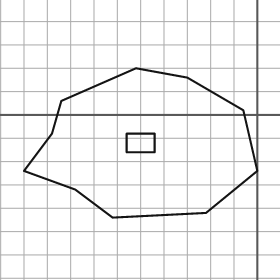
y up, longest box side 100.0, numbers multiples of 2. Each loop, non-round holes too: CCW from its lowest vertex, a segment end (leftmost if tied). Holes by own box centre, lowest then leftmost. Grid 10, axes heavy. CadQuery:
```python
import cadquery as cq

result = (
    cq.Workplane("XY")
    .moveTo(-62.0, -44.0)
    .lineTo(-22.0, -42.0)
    .lineTo(0.0, -24.0)
    .lineTo(-6.0, 2.0)
    .lineTo(-30.0, 16.0)
    .lineTo(-52.0, 20.0)
    .lineTo(-84.0, 6.0)
    .lineTo(-88.0, -8.0)
    .lineTo(-100.0, -24.0)
    .lineTo(-78.0, -32.0)
    .close()
    .moveTo(-56.0, -16.0)
    .lineTo(-44.0, -16.0)
    .lineTo(-44.0, -8.0)
    .lineTo(-56.0, -8.0)
    .close()
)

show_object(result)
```